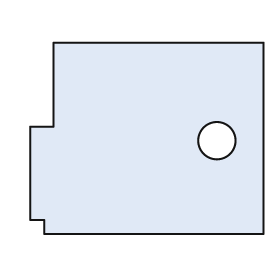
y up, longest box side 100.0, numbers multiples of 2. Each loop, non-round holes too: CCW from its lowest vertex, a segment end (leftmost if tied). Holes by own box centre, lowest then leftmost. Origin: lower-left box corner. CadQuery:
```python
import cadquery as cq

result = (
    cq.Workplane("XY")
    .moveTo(6.0, 0.0)
    .lineTo(100.0, 0.0)
    .lineTo(100.0, 82.0)
    .lineTo(10.0, 82.0)
    .lineTo(10.0, 46.0)
    .lineTo(0.0, 46.0)
    .lineTo(0.0, 6.0)
    .lineTo(6.0, 6.0)
    .close()
    .moveTo(80.0, 40.0)
    .circle(8.0)
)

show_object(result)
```